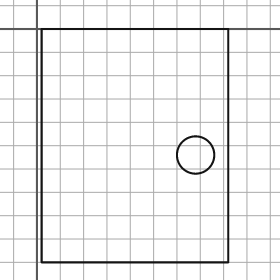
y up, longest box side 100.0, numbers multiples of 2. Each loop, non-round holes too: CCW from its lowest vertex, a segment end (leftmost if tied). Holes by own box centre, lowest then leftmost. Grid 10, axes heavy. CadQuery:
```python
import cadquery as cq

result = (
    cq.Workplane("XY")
    .moveTo(2.0, -100.0)
    .lineTo(82.0, -100.0)
    .lineTo(82.0, 0.0)
    .lineTo(2.0, 0.0)
    .close()
    .moveTo(68.0, -54.0)
    .circle(8.0)
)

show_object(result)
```